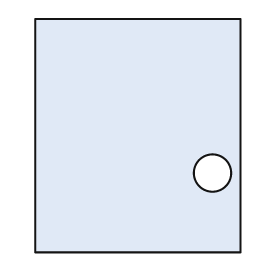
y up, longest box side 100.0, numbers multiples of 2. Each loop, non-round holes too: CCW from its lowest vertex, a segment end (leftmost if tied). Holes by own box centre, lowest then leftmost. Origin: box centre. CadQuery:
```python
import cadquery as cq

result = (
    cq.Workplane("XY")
    .moveTo(-44.0, -50.0)
    .lineTo(44.0, -50.0)
    .lineTo(44.0, 50.0)
    .lineTo(-44.0, 50.0)
    .close()
    .moveTo(32.0, -16.0)
    .circle(8.0)
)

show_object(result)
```